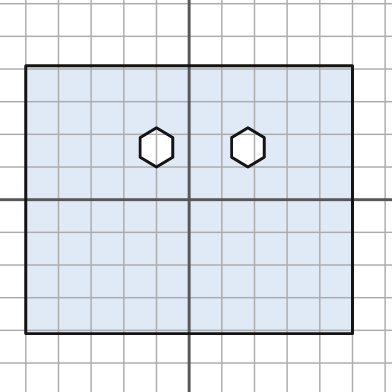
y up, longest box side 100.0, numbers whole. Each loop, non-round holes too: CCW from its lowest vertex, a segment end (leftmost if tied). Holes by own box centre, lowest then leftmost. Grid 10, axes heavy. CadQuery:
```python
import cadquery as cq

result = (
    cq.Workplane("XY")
    .moveTo(-50.0, -41.0)
    .lineTo(50.0, -41.0)
    .lineTo(50.0, 41.0)
    .lineTo(-50.0, 41.0)
    .close()
    .moveTo(-10.0, 10.0)
    .lineTo(-5.0, 13.0)
    .lineTo(-5.0, 19.0)
    .lineTo(-10.0, 22.0)
    .lineTo(-15.0, 19.0)
    .lineTo(-15.0, 13.0)
    .close()
    .moveTo(18.0, 10.0)
    .lineTo(23.0, 13.0)
    .lineTo(23.0, 19.0)
    .lineTo(18.0, 22.0)
    .lineTo(13.0, 19.0)
    .lineTo(13.0, 13.0)
    .close()
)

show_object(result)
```